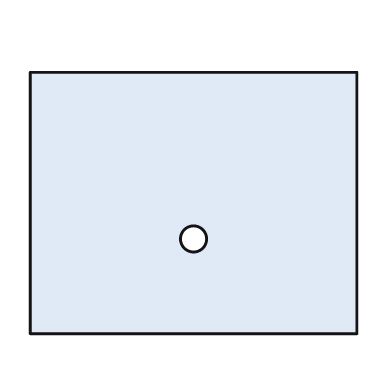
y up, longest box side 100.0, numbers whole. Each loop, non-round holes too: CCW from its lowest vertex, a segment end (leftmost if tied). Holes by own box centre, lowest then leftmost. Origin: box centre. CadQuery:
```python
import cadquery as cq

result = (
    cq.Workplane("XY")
    .moveTo(-50.0, -40.0)
    .lineTo(50.0, -40.0)
    .lineTo(50.0, 40.0)
    .lineTo(-50.0, 40.0)
    .close()
    .moveTo(0.0, -11.0)
    .circle(4.0)
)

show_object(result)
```